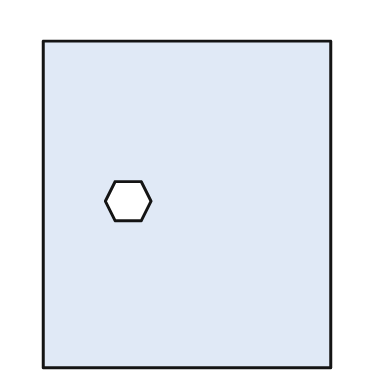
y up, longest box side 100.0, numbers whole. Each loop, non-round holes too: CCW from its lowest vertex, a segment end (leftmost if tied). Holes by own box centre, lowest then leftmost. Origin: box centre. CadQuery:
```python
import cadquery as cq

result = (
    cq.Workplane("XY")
    .moveTo(-44.0, -50.0)
    .lineTo(44.0, -50.0)
    .lineTo(44.0, 50.0)
    .lineTo(-44.0, 50.0)
    .close()
    .moveTo(-22.0, -5.0)
    .lineTo(-14.0, -5.0)
    .lineTo(-11.0, 1.0)
    .lineTo(-14.0, 7.0)
    .lineTo(-22.0, 7.0)
    .lineTo(-25.0, 1.0)
    .close()
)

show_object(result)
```